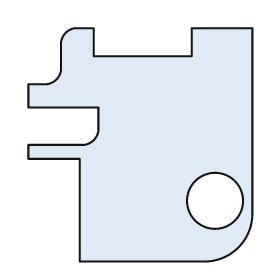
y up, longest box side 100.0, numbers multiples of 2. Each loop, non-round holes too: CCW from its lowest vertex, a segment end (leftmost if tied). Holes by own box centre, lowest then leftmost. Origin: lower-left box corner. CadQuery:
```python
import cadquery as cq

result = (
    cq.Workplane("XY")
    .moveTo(22.0, 0.0)
    .lineTo(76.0, 0.0)
    .threePointArc((90.0, 6.0), (96.0, 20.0))
    .lineTo(96.0, 100.0)
    .lineTo(70.0, 100.0)
    .lineTo(70.0, 88.0)
    .lineTo(28.0, 88.0)
    .lineTo(28.0, 100.0)
    .lineTo(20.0, 100.0)
    .threePointArc((16.0, 98.0), (14.0, 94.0))
    .lineTo(14.0, 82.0)
    .threePointArc((12.0, 78.0), (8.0, 76.0))
    .lineTo(0.0, 76.0)
    .lineTo(0.0, 66.0)
    .lineTo(30.0, 66.0)
    .lineTo(30.0, 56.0)
    .threePointArc((28.0, 52.0), (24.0, 50.0))
    .lineTo(0.0, 50.0)
    .lineTo(0.0, 44.0)
    .lineTo(22.0, 44.0)
    .close()
    .moveTo(80.0, 26.0)
    .circle(12.0)
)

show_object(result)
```